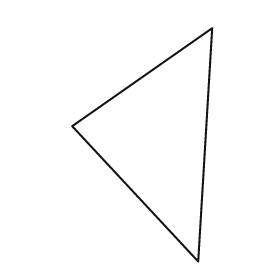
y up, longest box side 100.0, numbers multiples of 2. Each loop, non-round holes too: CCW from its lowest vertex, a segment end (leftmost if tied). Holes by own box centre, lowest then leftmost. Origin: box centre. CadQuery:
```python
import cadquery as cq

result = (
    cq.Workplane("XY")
    .moveTo(24.0, -50.0)
    .lineTo(30.0, 50.0)
    .lineTo(-30.0, 8.0)
    .close()
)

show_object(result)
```